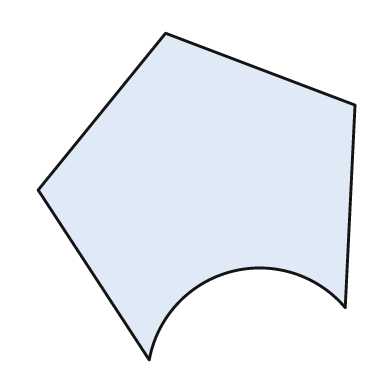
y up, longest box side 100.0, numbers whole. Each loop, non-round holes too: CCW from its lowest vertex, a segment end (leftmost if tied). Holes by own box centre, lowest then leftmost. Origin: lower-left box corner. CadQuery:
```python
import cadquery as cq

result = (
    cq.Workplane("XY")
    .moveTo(34.0, 0.0)
    .threePointArc((59.0, 27.0), (94.0, 16.0))
    .lineTo(97.0, 78.0)
    .lineTo(39.0, 100.0)
    .lineTo(0.0, 52.0)
    .close()
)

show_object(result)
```